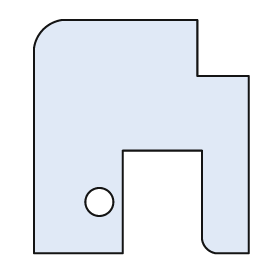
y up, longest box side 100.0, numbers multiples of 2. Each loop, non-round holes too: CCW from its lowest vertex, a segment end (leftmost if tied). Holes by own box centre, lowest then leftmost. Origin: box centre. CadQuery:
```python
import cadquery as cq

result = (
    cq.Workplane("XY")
    .moveTo(-46.0, -50.0)
    .lineTo(-8.0, -50.0)
    .lineTo(-8.0, -6.0)
    .lineTo(26.0, -6.0)
    .lineTo(26.0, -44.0)
    .threePointArc((28.0, -48.0), (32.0, -50.0))
    .lineTo(46.0, -50.0)
    .lineTo(46.0, 26.0)
    .lineTo(24.0, 26.0)
    .lineTo(24.0, 50.0)
    .lineTo(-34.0, 50.0)
    .threePointArc((-42.0, 46.0), (-46.0, 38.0))
    .close()
    .moveTo(-18.0, -28.0)
    .circle(6.0)
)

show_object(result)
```